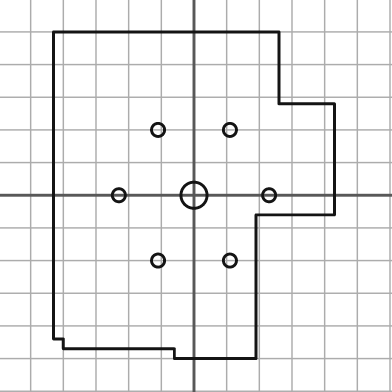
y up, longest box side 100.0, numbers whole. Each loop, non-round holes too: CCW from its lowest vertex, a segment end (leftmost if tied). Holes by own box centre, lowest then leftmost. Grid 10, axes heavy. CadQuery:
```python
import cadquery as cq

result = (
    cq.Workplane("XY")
    .moveTo(-6.0, -50.0)
    .lineTo(19.0, -50.0)
    .lineTo(19.0, -6.0)
    .lineTo(43.0, -6.0)
    .lineTo(43.0, 28.0)
    .lineTo(26.0, 28.0)
    .lineTo(26.0, 50.0)
    .lineTo(-43.0, 50.0)
    .lineTo(-43.0, -44.0)
    .lineTo(-40.0, -44.0)
    .lineTo(-40.0, -47.0)
    .lineTo(-6.0, -47.0)
    .close()
    .moveTo(-11.0, -20.0)
    .circle(2.0)
    .moveTo(11.0, -20.0)
    .circle(2.0)
    .moveTo(-23.0, 0.0)
    .circle(2.0)
    .moveTo(0.0, 0.0)
    .circle(4.0)
    .moveTo(23.0, 0.0)
    .circle(2.0)
    .moveTo(-11.0, 20.0)
    .circle(2.0)
    .moveTo(11.0, 20.0)
    .circle(2.0)
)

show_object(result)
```